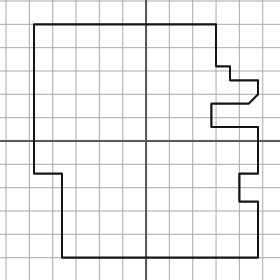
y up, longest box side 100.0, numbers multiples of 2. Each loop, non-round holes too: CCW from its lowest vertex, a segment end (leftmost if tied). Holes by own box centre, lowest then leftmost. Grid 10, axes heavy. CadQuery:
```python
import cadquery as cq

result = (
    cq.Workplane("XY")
    .moveTo(-36.0, -50.0)
    .lineTo(48.0, -50.0)
    .lineTo(48.0, -26.0)
    .lineTo(40.0, -26.0)
    .lineTo(40.0, -14.0)
    .lineTo(48.0, -14.0)
    .lineTo(48.0, 6.0)
    .lineTo(28.0, 6.0)
    .lineTo(28.0, 16.0)
    .lineTo(44.0, 16.0)
    .lineTo(48.0, 20.0)
    .lineTo(48.0, 26.0)
    .lineTo(36.0, 26.0)
    .lineTo(36.0, 32.0)
    .lineTo(30.0, 32.0)
    .lineTo(30.0, 50.0)
    .lineTo(-48.0, 50.0)
    .lineTo(-48.0, -14.0)
    .lineTo(-36.0, -14.0)
    .close()
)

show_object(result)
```